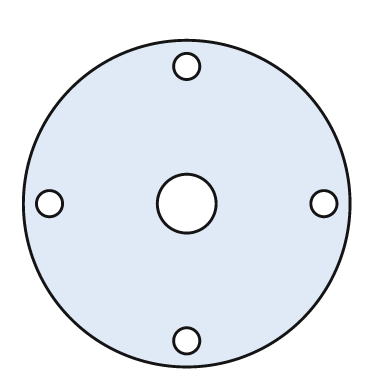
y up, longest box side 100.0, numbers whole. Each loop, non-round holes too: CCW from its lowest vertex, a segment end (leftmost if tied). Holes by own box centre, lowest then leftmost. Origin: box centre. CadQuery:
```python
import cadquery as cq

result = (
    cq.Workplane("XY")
    .moveTo(0.0, 0.0)
    .circle(50.0)
    .moveTo(0.0, -42.0)
    .circle(4.0)
    .moveTo(-42.0, 0.0)
    .circle(4.0)
    .moveTo(0.0, 0.0)
    .circle(9.0)
    .moveTo(42.0, 0.0)
    .circle(4.0)
    .moveTo(0.0, 42.0)
    .circle(4.0)
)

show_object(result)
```